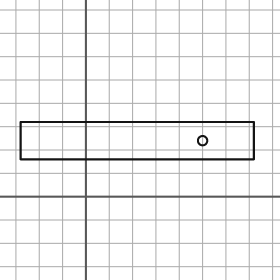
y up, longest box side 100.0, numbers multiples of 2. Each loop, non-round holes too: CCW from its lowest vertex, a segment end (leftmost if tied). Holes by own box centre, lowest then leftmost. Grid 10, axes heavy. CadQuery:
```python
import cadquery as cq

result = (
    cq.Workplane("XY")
    .moveTo(-28.0, 16.0)
    .lineTo(72.0, 16.0)
    .lineTo(72.0, 32.0)
    .lineTo(-28.0, 32.0)
    .close()
    .moveTo(50.0, 24.0)
    .circle(2.0)
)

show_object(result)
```